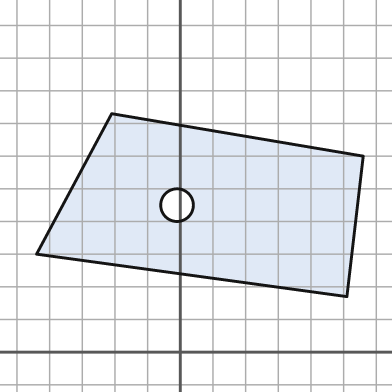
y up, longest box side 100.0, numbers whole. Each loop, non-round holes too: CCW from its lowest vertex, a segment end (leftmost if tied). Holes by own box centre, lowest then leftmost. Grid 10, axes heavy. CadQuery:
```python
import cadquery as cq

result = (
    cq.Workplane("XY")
    .moveTo(51.0, 17.0)
    .lineTo(56.0, 60.0)
    .lineTo(-21.0, 73.0)
    .lineTo(-44.0, 30.0)
    .close()
    .moveTo(-1.0, 45.0)
    .circle(5.0)
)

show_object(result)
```